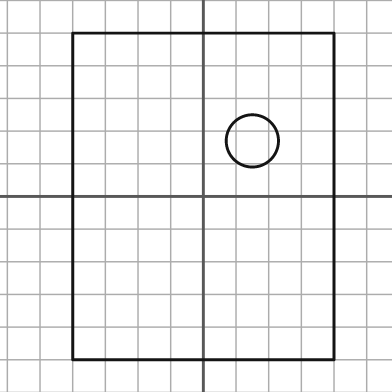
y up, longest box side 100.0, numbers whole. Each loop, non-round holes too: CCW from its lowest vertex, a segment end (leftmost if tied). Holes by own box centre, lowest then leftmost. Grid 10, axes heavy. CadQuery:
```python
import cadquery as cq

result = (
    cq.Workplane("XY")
    .moveTo(-40.0, -50.0)
    .lineTo(40.0, -50.0)
    .lineTo(40.0, 50.0)
    .lineTo(-40.0, 50.0)
    .close()
    .moveTo(15.0, 17.0)
    .circle(8.0)
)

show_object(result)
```